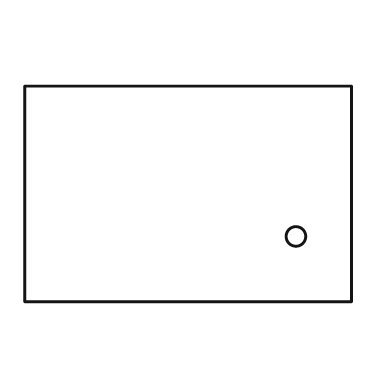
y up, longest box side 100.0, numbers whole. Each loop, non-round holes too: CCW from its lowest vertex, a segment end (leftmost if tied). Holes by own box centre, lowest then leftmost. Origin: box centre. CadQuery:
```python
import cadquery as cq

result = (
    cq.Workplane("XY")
    .moveTo(-50.0, -33.0)
    .lineTo(50.0, -33.0)
    .lineTo(50.0, 33.0)
    .lineTo(-50.0, 33.0)
    .close()
    .moveTo(33.0, -13.0)
    .circle(3.0)
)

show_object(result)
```